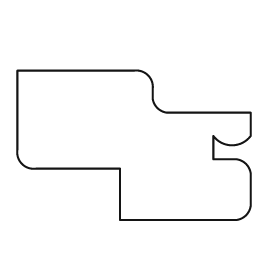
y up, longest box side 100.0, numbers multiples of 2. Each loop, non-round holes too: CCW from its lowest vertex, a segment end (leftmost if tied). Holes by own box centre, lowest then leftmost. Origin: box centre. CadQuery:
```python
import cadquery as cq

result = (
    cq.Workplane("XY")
    .moveTo(-6.0, -32.0)
    .lineTo(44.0, -32.0)
    .threePointArc((48.0, -30.0), (50.0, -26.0))
    .lineTo(50.0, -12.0)
    .threePointArc((48.0, -8.0), (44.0, -6.0))
    .lineTo(34.0, -6.0)
    .lineTo(34.0, 4.0)
    .threePointArc((42.0, 0.0), (50.0, 4.0))
    .lineTo(50.0, 14.0)
    .lineTo(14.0, 14.0)
    .threePointArc((10.0, 16.0), (8.0, 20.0))
    .lineTo(8.0, 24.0)
    .threePointArc((6.0, 30.0), (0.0, 32.0))
    .lineTo(-50.0, 32.0)
    .lineTo(-50.0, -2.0)
    .threePointArc((-48.0, -8.0), (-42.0, -10.0))
    .lineTo(-6.0, -10.0)
    .close()
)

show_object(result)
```